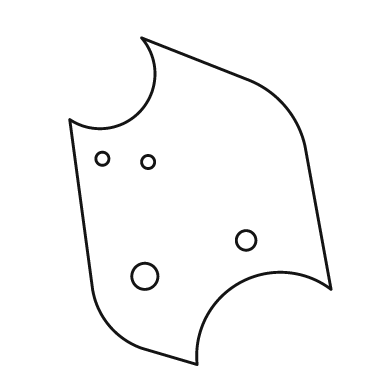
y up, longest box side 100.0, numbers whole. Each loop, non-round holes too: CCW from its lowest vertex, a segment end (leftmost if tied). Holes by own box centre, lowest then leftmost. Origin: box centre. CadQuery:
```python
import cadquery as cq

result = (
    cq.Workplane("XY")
    .moveTo(-1.0, -50.0)
    .threePointArc((12.0, -25.0), (40.0, -27.0))
    .lineTo(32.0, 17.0)
    .threePointArc((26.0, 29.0), (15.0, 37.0))
    .lineTo(-18.0, 50.0)
    .threePointArc((-18.0, 28.0), (-40.0, 25.0))
    .lineTo(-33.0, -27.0)
    .threePointArc((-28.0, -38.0), (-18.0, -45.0))
    .close()
    .moveTo(-17.0, -23.0)
    .circle(4.0)
    .moveTo(14.0, -12.0)
    .circle(3.0)
    .moveTo(-16.0, 12.0)
    .circle(2.0)
    .moveTo(-30.0, 13.0)
    .circle(2.0)
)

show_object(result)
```